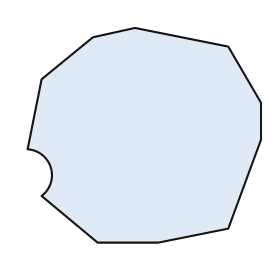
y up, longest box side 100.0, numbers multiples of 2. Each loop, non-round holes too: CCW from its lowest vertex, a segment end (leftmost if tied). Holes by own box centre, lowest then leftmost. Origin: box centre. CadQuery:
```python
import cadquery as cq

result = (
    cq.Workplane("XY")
    .moveTo(-20.0, -46.0)
    .lineTo(6.0, -46.0)
    .lineTo(36.0, -40.0)
    .lineTo(50.0, -2.0)
    .lineTo(50.0, 14.0)
    .lineTo(36.0, 38.0)
    .lineTo(-4.0, 46.0)
    .lineTo(-22.0, 42.0)
    .lineTo(-44.0, 24.0)
    .lineTo(-50.0, -6.0)
    .threePointArc((-40.0, -14.0), (-44.0, -26.0))
    .close()
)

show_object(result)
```